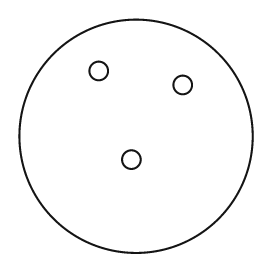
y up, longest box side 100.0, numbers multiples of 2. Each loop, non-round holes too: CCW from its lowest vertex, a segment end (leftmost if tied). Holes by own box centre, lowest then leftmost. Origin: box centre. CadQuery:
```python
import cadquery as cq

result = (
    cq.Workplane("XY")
    .moveTo(0.0, 0.0)
    .circle(50.0)
    .moveTo(-2.0, -10.0)
    .circle(4.0)
    .moveTo(20.0, 22.0)
    .circle(4.0)
    .moveTo(-16.0, 28.0)
    .circle(4.0)
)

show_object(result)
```